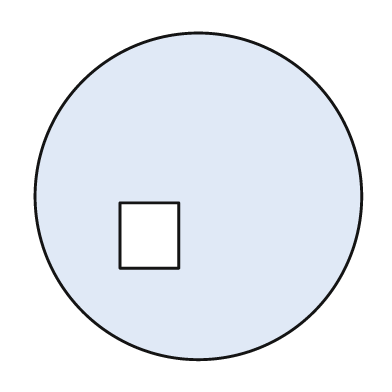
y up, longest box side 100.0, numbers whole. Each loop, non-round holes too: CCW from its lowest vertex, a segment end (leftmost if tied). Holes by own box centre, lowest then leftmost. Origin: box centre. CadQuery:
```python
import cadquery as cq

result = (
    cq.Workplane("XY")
    .moveTo(0.0, 0.0)
    .circle(50.0)
    .moveTo(-24.0, -22.0)
    .lineTo(-6.0, -22.0)
    .lineTo(-6.0, -2.0)
    .lineTo(-24.0, -2.0)
    .close()
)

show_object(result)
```